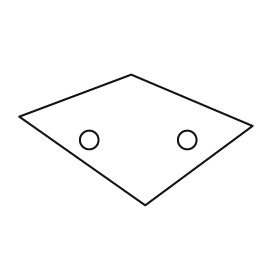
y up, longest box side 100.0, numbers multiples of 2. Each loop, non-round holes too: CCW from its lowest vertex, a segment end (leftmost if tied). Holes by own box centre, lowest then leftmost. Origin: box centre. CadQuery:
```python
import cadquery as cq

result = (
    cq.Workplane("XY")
    .moveTo(4.0, -28.0)
    .lineTo(50.0, 6.0)
    .lineTo(-2.0, 28.0)
    .lineTo(-50.0, 10.0)
    .close()
    .moveTo(-20.0, 0.0)
    .circle(4.0)
    .moveTo(22.0, 0.0)
    .circle(4.0)
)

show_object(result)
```